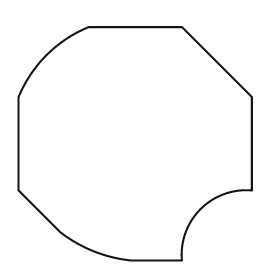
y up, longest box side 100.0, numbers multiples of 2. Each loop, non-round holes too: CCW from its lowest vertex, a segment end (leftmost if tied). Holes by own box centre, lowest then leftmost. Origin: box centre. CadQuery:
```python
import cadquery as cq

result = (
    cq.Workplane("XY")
    .moveTo(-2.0, -50.0)
    .lineTo(20.0, -50.0)
    .threePointArc((28.0, -28.0), (50.0, -20.0))
    .lineTo(50.0, 20.0)
    .lineTo(20.0, 50.0)
    .lineTo(-20.0, 50.0)
    .threePointArc((-38.0, 38.0), (-50.0, 20.0))
    .lineTo(-50.0, -20.0)
    .lineTo(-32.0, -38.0)
    .threePointArc((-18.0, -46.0), (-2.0, -50.0))
    .close()
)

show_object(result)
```